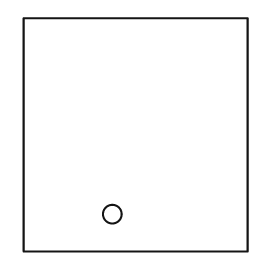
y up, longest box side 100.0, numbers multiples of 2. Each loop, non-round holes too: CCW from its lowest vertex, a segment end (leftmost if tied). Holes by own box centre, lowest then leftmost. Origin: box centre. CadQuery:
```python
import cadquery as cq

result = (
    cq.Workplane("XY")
    .moveTo(-48.0, -50.0)
    .lineTo(48.0, -50.0)
    .lineTo(48.0, 50.0)
    .lineTo(-48.0, 50.0)
    .close()
    .moveTo(-10.0, -34.0)
    .circle(4.0)
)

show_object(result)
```